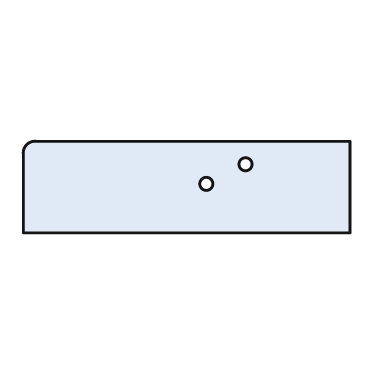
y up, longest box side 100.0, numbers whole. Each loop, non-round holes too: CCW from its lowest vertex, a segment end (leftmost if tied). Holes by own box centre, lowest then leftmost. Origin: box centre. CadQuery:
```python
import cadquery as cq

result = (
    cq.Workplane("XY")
    .moveTo(-50.0, -14.0)
    .lineTo(50.0, -14.0)
    .lineTo(50.0, 14.0)
    .lineTo(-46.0, 14.0)
    .threePointArc((-49.0, 13.0), (-50.0, 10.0))
    .close()
    .moveTo(6.0, 1.0)
    .circle(2.0)
    .moveTo(18.0, 7.0)
    .circle(2.0)
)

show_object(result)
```